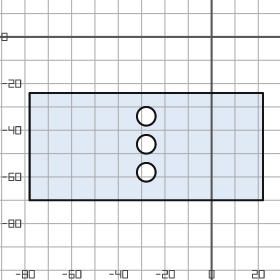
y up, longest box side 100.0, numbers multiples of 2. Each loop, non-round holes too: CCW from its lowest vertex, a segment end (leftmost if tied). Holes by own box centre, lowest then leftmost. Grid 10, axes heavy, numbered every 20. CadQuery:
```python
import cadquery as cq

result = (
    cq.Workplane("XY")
    .moveTo(-78.0, -70.0)
    .lineTo(22.0, -70.0)
    .lineTo(22.0, -24.0)
    .lineTo(-78.0, -24.0)
    .close()
    .moveTo(-28.0, -58.0)
    .circle(4.0)
    .moveTo(-28.0, -46.0)
    .circle(4.0)
    .moveTo(-28.0, -34.0)
    .circle(4.0)
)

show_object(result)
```